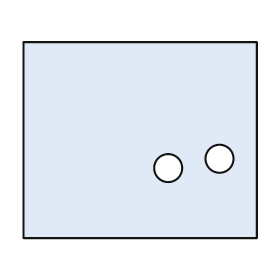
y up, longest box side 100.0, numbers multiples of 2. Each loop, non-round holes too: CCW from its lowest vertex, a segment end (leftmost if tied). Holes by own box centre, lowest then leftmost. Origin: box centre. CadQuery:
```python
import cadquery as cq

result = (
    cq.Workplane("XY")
    .moveTo(-50.0, -42.0)
    .lineTo(50.0, -42.0)
    .lineTo(50.0, 42.0)
    .lineTo(-50.0, 42.0)
    .close()
    .moveTo(12.0, -12.0)
    .circle(6.0)
    .moveTo(34.0, -8.0)
    .circle(6.0)
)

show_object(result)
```